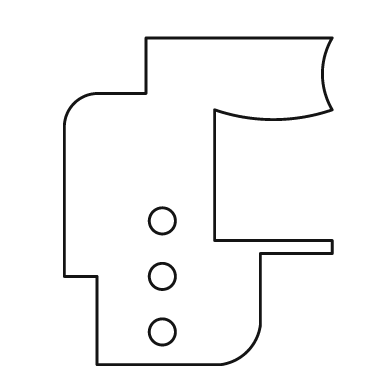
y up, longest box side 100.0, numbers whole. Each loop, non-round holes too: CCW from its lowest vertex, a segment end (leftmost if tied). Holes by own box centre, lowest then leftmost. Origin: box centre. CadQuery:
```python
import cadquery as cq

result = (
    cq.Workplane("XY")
    .moveTo(-31.0, -50.0)
    .lineTo(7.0, -50.0)
    .threePointArc((15.0, -46.0), (19.0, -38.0))
    .lineTo(19.0, -16.0)
    .lineTo(41.0, -16.0)
    .lineTo(41.0, -12.0)
    .lineTo(5.0, -12.0)
    .lineTo(5.0, 28.0)
    .threePointArc((23.0, 25.0), (41.0, 28.0))
    .threePointArc((38.0, 39.0), (41.0, 50.0))
    .lineTo(-16.0, 50.0)
    .lineTo(-16.0, 33.0)
    .lineTo(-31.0, 33.0)
    .threePointArc((-38.0, 30.0), (-41.0, 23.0))
    .lineTo(-41.0, -23.0)
    .lineTo(-31.0, -23.0)
    .close()
    .moveTo(-11.0, -40.0)
    .circle(4.0)
    .moveTo(-11.0, -23.0)
    .circle(4.0)
    .moveTo(-11.0, -6.0)
    .circle(4.0)
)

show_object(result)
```